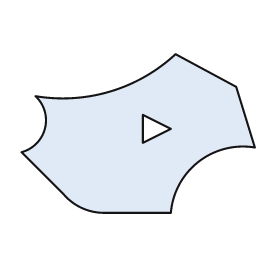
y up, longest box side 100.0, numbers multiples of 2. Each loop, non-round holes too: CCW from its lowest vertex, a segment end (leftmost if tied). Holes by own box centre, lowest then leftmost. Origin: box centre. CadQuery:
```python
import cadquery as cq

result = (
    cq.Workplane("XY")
    .moveTo(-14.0, -34.0)
    .lineTo(14.0, -34.0)
    .threePointArc((26.0, -12.0), (50.0, -6.0))
    .lineTo(42.0, 20.0)
    .lineTo(16.0, 34.0)
    .threePointArc((-12.0, 18.0), (-44.0, 16.0))
    .threePointArc((-40.0, 2.0), (-50.0, -8.0))
    .lineTo(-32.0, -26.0)
    .threePointArc((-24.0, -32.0), (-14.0, -34.0))
    .close()
    .moveTo(2.0, -4.0)
    .lineTo(14.0, 2.0)
    .lineTo(2.0, 8.0)
    .close()
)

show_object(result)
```